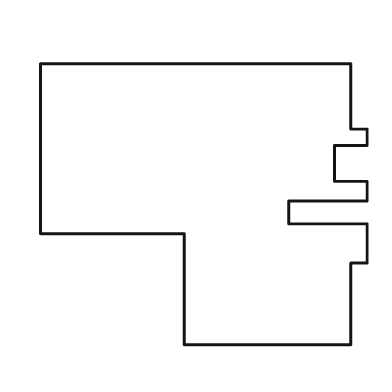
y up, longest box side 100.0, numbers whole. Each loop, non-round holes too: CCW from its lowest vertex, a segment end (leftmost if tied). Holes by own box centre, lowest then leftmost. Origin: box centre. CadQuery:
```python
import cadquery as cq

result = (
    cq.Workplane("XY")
    .moveTo(-6.0, -43.0)
    .lineTo(45.0, -43.0)
    .lineTo(45.0, -18.0)
    .lineTo(50.0, -18.0)
    .lineTo(50.0, -6.0)
    .lineTo(26.0, -6.0)
    .lineTo(26.0, 1.0)
    .lineTo(50.0, 1.0)
    .lineTo(50.0, 7.0)
    .lineTo(40.0, 7.0)
    .lineTo(40.0, 18.0)
    .lineTo(50.0, 18.0)
    .lineTo(50.0, 23.0)
    .lineTo(45.0, 23.0)
    .lineTo(45.0, 43.0)
    .lineTo(-50.0, 43.0)
    .lineTo(-50.0, -9.0)
    .lineTo(-6.0, -9.0)
    .close()
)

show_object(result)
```